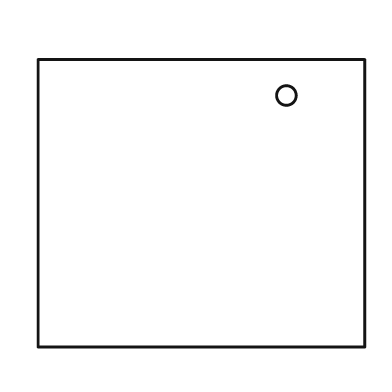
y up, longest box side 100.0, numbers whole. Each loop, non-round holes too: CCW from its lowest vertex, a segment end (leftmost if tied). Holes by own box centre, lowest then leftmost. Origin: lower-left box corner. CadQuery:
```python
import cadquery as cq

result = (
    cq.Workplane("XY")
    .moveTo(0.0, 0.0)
    .lineTo(100.0, 0.0)
    .lineTo(100.0, 88.0)
    .lineTo(0.0, 88.0)
    .close()
    .moveTo(76.0, 77.0)
    .circle(3.0)
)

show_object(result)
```